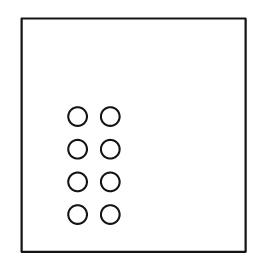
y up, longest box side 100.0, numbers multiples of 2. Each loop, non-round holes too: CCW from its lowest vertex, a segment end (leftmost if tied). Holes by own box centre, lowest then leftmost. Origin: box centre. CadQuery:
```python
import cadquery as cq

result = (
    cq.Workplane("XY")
    .moveTo(-48.0, -50.0)
    .lineTo(48.0, -50.0)
    .lineTo(48.0, 50.0)
    .lineTo(-48.0, 50.0)
    .close()
    .moveTo(-24.0, -34.0)
    .circle(4.0)
    .moveTo(-10.0, -34.0)
    .circle(4.0)
    .moveTo(-24.0, -20.0)
    .circle(4.0)
    .moveTo(-10.0, -20.0)
    .circle(4.0)
    .moveTo(-24.0, -6.0)
    .circle(4.0)
    .moveTo(-10.0, -6.0)
    .circle(4.0)
    .moveTo(-24.0, 8.0)
    .circle(4.0)
    .moveTo(-10.0, 8.0)
    .circle(4.0)
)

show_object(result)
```